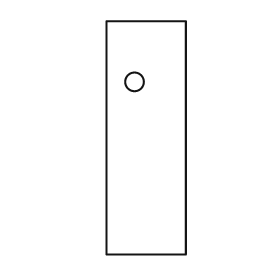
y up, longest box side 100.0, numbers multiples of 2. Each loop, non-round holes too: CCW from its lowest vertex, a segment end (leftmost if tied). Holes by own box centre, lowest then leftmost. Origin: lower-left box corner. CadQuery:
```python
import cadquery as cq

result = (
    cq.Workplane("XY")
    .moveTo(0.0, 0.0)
    .lineTo(34.0, 0.0)
    .lineTo(34.0, 100.0)
    .lineTo(0.0, 100.0)
    .close()
    .moveTo(12.0, 74.0)
    .circle(4.0)
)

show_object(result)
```